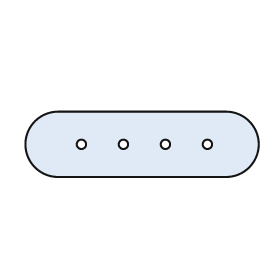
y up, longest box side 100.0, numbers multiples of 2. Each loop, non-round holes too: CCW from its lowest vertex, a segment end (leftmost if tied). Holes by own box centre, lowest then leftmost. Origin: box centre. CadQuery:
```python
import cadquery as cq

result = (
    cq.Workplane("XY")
    .moveTo(-36.0, -14.0)
    .lineTo(36.0, -14.0)
    .threePointArc((50.0, 0.0), (36.0, 14.0))
    .lineTo(-36.0, 14.0)
    .threePointArc((-50.0, 0.0), (-36.0, -14.0))
    .close()
    .moveTo(-26.0, 0.0)
    .circle(2.0)
    .moveTo(-8.0, 0.0)
    .circle(2.0)
    .moveTo(10.0, 0.0)
    .circle(2.0)
    .moveTo(28.0, 0.0)
    .circle(2.0)
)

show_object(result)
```